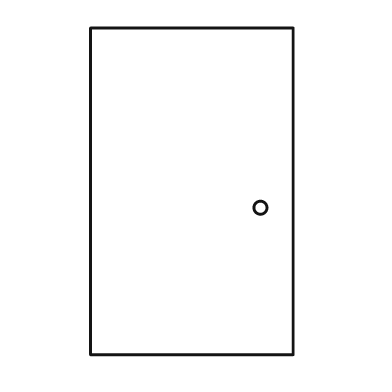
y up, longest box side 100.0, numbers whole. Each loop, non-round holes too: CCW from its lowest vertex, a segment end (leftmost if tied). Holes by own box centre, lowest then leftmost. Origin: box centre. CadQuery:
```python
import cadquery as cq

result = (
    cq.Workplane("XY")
    .moveTo(-31.0, -50.0)
    .lineTo(31.0, -50.0)
    .lineTo(31.0, 50.0)
    .lineTo(-31.0, 50.0)
    .close()
    .moveTo(21.0, -5.0)
    .circle(2.0)
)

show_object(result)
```